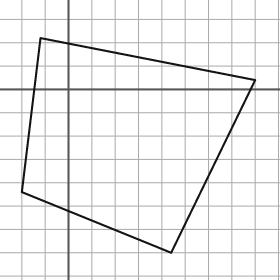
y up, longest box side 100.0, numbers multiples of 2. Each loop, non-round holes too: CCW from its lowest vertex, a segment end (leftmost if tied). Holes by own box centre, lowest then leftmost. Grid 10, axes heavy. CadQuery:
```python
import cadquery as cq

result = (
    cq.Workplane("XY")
    .moveTo(44.0, -70.0)
    .lineTo(80.0, 4.0)
    .lineTo(-12.0, 22.0)
    .lineTo(-20.0, -44.0)
    .close()
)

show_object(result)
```